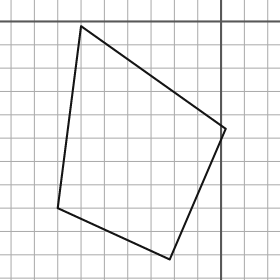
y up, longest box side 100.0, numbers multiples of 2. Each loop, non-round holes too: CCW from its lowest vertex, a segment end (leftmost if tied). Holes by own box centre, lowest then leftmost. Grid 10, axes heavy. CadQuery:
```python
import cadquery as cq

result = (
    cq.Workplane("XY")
    .moveTo(-22.0, -102.0)
    .lineTo(2.0, -46.0)
    .lineTo(-60.0, -2.0)
    .lineTo(-70.0, -80.0)
    .close()
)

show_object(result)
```